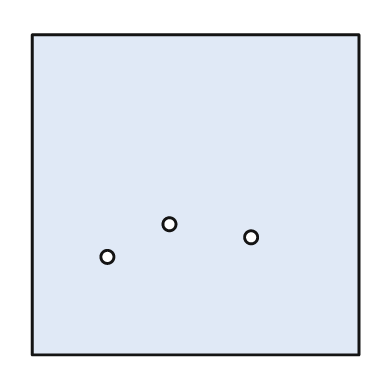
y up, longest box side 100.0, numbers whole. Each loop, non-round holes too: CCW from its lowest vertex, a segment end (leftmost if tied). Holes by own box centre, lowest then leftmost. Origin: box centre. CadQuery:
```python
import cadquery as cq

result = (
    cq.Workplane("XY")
    .moveTo(-50.0, -49.0)
    .lineTo(50.0, -49.0)
    .lineTo(50.0, 49.0)
    .lineTo(-50.0, 49.0)
    .close()
    .moveTo(-27.0, -19.0)
    .circle(2.0)
    .moveTo(17.0, -13.0)
    .circle(2.0)
    .moveTo(-8.0, -9.0)
    .circle(2.0)
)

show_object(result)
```